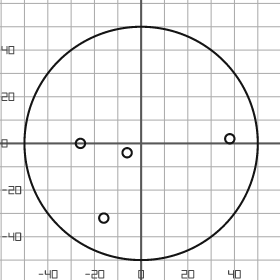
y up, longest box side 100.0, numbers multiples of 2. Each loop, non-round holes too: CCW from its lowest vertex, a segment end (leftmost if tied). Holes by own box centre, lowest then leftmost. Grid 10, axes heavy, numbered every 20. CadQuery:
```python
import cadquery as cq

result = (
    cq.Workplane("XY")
    .moveTo(0.0, 0.0)
    .circle(50.0)
    .moveTo(-16.0, -32.0)
    .circle(2.0)
    .moveTo(-6.0, -4.0)
    .circle(2.0)
    .moveTo(-26.0, 0.0)
    .circle(2.0)
    .moveTo(38.0, 2.0)
    .circle(2.0)
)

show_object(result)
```